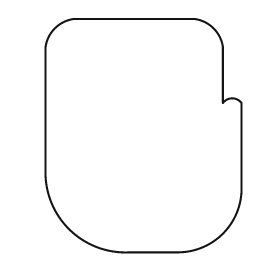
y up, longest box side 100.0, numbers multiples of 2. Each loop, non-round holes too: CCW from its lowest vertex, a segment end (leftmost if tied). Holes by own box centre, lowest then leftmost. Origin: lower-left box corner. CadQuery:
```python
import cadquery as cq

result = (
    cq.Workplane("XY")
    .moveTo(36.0, 0.0)
    .lineTo(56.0, 0.0)
    .threePointArc((76.0, 8.0), (84.0, 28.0))
    .lineTo(84.0, 64.0)
    .threePointArc((80.0, 66.0), (76.0, 64.0))
    .lineTo(76.0, 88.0)
    .threePointArc((72.0, 96.0), (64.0, 100.0))
    .lineTo(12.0, 100.0)
    .threePointArc((4.0, 96.0), (0.0, 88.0))
    .lineTo(0.0, 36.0)
    .threePointArc((10.0, 10.0), (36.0, 0.0))
    .close()
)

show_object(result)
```